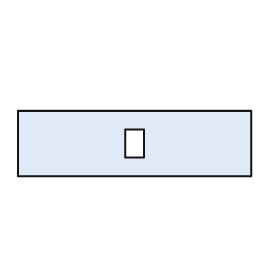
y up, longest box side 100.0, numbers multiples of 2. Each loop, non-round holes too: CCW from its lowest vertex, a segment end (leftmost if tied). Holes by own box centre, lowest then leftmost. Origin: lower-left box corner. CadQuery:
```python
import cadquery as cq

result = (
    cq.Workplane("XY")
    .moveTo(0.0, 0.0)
    .lineTo(100.0, 0.0)
    .lineTo(100.0, 28.0)
    .lineTo(0.0, 28.0)
    .close()
    .moveTo(46.0, 8.0)
    .lineTo(54.0, 8.0)
    .lineTo(54.0, 20.0)
    .lineTo(46.0, 20.0)
    .close()
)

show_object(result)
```